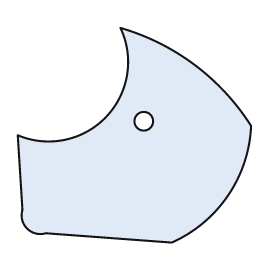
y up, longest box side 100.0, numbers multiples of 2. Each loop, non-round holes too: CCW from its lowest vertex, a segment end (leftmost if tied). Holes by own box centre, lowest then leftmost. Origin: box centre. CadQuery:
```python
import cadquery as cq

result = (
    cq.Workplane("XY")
    .moveTo(16.0, -46.0)
    .threePointArc((40.0, -26.0), (50.0, 4.0))
    .threePointArc((26.0, 30.0), (-6.0, 46.0))
    .threePointArc((-12.0, 8.0), (-50.0, 0.0))
    .lineTo(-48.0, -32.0)
    .threePointArc((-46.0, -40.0), (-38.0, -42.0))
    .close()
    .moveTo(4.0, 6.0)
    .circle(4.0)
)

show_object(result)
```